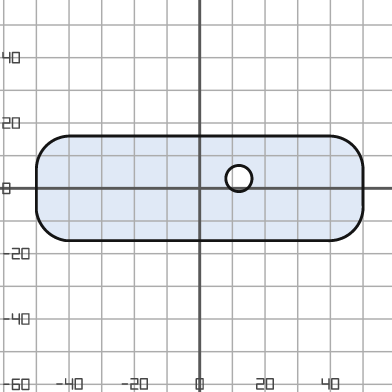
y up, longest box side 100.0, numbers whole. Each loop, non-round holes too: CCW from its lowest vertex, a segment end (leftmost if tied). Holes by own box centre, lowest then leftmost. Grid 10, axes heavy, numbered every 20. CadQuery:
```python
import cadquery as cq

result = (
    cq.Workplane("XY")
    .moveTo(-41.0, -16.0)
    .lineTo(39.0, -16.0)
    .threePointArc((47.0, -13.0), (50.0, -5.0))
    .lineTo(50.0, 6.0)
    .threePointArc((47.0, 13.0), (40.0, 16.0))
    .lineTo(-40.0, 16.0)
    .threePointArc((-47.0, 13.0), (-50.0, 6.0))
    .lineTo(-50.0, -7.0)
    .threePointArc((-47.0, -13.0), (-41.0, -16.0))
    .close()
    .moveTo(12.0, 3.0)
    .circle(4.0)
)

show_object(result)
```